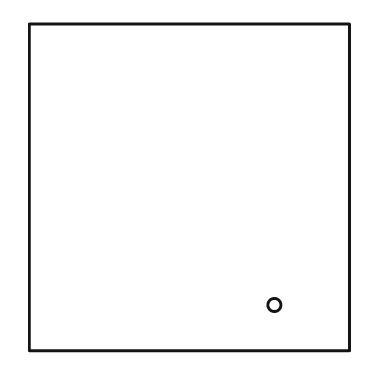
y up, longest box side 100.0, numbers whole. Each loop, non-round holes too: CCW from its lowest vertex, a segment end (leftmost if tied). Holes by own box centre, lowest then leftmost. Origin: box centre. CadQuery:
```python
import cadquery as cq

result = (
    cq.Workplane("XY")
    .moveTo(-49.0, -50.0)
    .lineTo(49.0, -50.0)
    .lineTo(49.0, 50.0)
    .lineTo(-49.0, 50.0)
    .close()
    .moveTo(26.0, -36.0)
    .circle(2.0)
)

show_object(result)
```